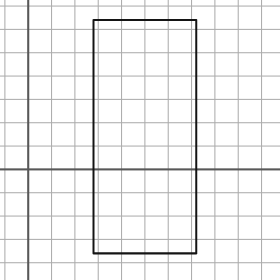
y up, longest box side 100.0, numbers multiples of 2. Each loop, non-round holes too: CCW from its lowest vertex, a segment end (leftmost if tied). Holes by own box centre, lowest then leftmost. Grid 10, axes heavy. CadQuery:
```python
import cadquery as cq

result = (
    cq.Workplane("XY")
    .moveTo(28.0, -36.0)
    .lineTo(72.0, -36.0)
    .lineTo(72.0, 64.0)
    .lineTo(28.0, 64.0)
    .close()
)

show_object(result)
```